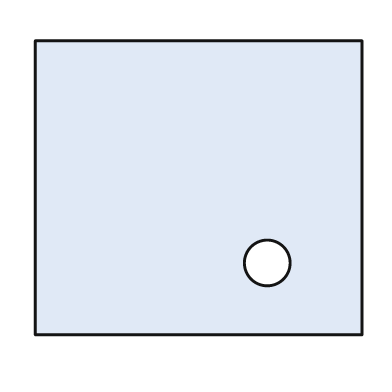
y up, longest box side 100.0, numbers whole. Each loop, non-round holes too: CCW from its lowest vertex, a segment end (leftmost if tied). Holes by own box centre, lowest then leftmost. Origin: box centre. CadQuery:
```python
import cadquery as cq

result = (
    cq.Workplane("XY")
    .moveTo(-50.0, -45.0)
    .lineTo(50.0, -45.0)
    .lineTo(50.0, 45.0)
    .lineTo(-50.0, 45.0)
    .close()
    .moveTo(21.0, -23.0)
    .circle(7.0)
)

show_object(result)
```